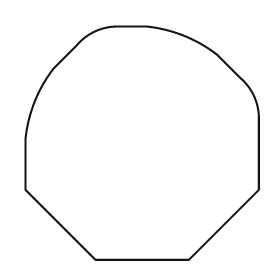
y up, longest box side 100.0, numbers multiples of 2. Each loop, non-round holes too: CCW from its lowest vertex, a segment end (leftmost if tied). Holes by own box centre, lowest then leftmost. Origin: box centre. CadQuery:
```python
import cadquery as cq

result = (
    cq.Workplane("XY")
    .moveTo(-20.0, -50.0)
    .lineTo(20.0, -50.0)
    .lineTo(50.0, -20.0)
    .lineTo(50.0, 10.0)
    .threePointArc((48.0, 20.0), (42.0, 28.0))
    .lineTo(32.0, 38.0)
    .threePointArc((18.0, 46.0), (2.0, 50.0))
    .lineTo(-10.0, 50.0)
    .threePointArc((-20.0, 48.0), (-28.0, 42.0))
    .lineTo(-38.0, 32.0)
    .threePointArc((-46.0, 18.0), (-50.0, 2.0))
    .lineTo(-50.0, -20.0)
    .close()
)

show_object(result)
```